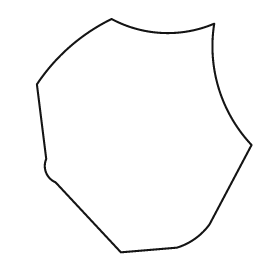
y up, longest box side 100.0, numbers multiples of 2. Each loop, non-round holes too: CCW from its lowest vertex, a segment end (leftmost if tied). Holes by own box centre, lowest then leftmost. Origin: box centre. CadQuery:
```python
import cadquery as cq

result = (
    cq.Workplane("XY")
    .moveTo(-10.0, -50.0)
    .lineTo(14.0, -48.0)
    .threePointArc((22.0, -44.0), (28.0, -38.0))
    .lineTo(46.0, -4.0)
    .threePointArc((32.0, 20.0), (30.0, 48.0))
    .threePointArc((8.0, 44.0), (-14.0, 50.0))
    .threePointArc((-32.0, 38.0), (-46.0, 22.0))
    .lineTo(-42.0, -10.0)
    .threePointArc((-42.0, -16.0), (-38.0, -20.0))
    .close()
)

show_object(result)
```